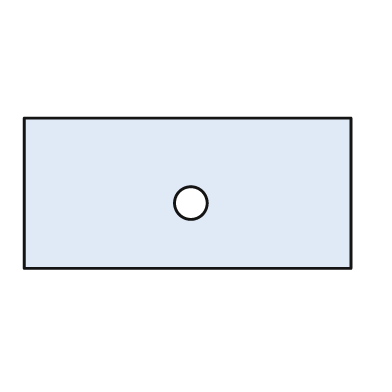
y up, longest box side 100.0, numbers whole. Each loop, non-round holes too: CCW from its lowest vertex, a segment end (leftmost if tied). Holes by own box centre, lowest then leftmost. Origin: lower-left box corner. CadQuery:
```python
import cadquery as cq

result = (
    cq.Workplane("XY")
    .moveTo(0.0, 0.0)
    .lineTo(100.0, 0.0)
    .lineTo(100.0, 46.0)
    .lineTo(0.0, 46.0)
    .close()
    .moveTo(51.0, 20.0)
    .circle(5.0)
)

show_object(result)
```